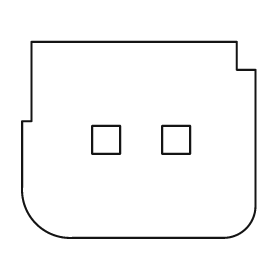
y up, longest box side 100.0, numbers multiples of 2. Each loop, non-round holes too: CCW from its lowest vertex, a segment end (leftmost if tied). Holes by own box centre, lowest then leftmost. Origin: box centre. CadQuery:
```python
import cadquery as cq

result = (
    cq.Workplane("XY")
    .moveTo(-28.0, -42.0)
    .lineTo(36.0, -42.0)
    .threePointArc((46.0, -38.0), (50.0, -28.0))
    .lineTo(50.0, 30.0)
    .lineTo(42.0, 30.0)
    .lineTo(42.0, 42.0)
    .lineTo(-46.0, 42.0)
    .lineTo(-46.0, 8.0)
    .lineTo(-50.0, 8.0)
    .lineTo(-50.0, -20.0)
    .threePointArc((-44.0, -36.0), (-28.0, -42.0))
    .close()
    .moveTo(-20.0, -6.0)
    .lineTo(-8.0, -6.0)
    .lineTo(-8.0, 6.0)
    .lineTo(-20.0, 6.0)
    .close()
    .moveTo(10.0, -6.0)
    .lineTo(22.0, -6.0)
    .lineTo(22.0, 6.0)
    .lineTo(10.0, 6.0)
    .close()
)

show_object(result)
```